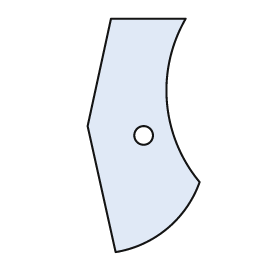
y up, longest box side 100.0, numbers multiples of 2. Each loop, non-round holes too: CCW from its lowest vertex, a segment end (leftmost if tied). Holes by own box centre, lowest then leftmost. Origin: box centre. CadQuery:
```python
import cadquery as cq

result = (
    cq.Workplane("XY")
    .moveTo(-12.0, -50.0)
    .threePointArc((10.0, -40.0), (24.0, -20.0))
    .threePointArc((10.0, 14.0), (18.0, 50.0))
    .lineTo(-14.0, 50.0)
    .lineTo(-24.0, 4.0)
    .close()
    .moveTo(0.0, 0.0)
    .circle(4.0)
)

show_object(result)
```